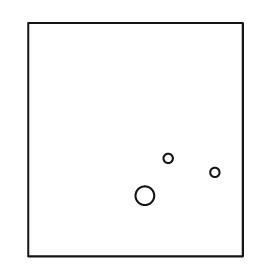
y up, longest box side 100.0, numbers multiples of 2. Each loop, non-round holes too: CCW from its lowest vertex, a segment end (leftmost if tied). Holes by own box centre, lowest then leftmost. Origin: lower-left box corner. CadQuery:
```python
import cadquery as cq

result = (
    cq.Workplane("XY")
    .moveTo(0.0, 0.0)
    .lineTo(92.0, 0.0)
    .lineTo(92.0, 100.0)
    .lineTo(0.0, 100.0)
    .close()
    .moveTo(50.0, 26.0)
    .circle(4.0)
    .moveTo(80.0, 36.0)
    .circle(2.0)
    .moveTo(60.0, 42.0)
    .circle(2.0)
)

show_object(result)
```